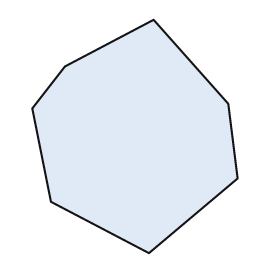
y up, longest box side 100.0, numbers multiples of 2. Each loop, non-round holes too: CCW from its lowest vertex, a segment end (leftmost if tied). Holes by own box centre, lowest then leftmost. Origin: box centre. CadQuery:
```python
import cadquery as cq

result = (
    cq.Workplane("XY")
    .moveTo(6.0, -50.0)
    .lineTo(44.0, -18.0)
    .lineTo(40.0, 14.0)
    .lineTo(8.0, 50.0)
    .lineTo(-30.0, 30.0)
    .lineTo(-44.0, 12.0)
    .lineTo(-36.0, -28.0)
    .close()
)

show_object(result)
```